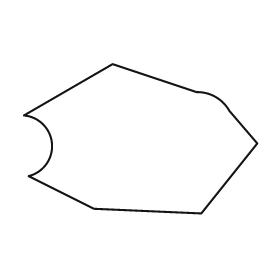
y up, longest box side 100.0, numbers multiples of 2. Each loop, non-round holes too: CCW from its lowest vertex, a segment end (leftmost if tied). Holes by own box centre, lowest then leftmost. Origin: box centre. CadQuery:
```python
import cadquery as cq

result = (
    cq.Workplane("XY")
    .moveTo(26.0, -32.0)
    .lineTo(50.0, -2.0)
    .lineTo(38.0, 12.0)
    .threePointArc((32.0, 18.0), (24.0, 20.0))
    .lineTo(-12.0, 32.0)
    .lineTo(-50.0, 10.0)
    .threePointArc((-38.0, -2.0), (-48.0, -16.0))
    .lineTo(-20.0, -30.0)
    .close()
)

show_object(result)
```